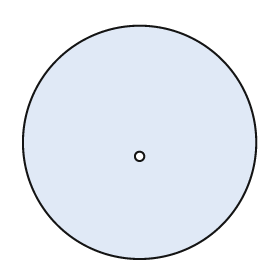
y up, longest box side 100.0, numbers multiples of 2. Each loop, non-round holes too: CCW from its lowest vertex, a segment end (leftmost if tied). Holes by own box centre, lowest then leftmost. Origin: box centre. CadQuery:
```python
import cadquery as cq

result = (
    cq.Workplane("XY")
    .moveTo(0.0, 0.0)
    .circle(50.0)
    .moveTo(0.0, -6.0)
    .circle(2.0)
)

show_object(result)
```